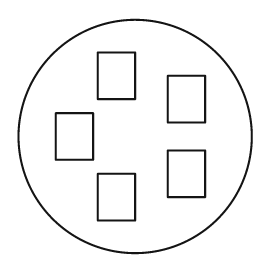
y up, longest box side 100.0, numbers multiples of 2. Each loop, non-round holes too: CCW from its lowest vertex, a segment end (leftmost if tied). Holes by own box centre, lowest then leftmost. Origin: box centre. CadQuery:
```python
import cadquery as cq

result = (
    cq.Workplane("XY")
    .moveTo(0.0, 0.0)
    .circle(50.0)
    .moveTo(-16.0, -36.0)
    .lineTo(0.0, -36.0)
    .lineTo(0.0, -16.0)
    .lineTo(-16.0, -16.0)
    .close()
    .moveTo(14.0, -26.0)
    .lineTo(30.0, -26.0)
    .lineTo(30.0, -6.0)
    .lineTo(14.0, -6.0)
    .close()
    .moveTo(-34.0, -10.0)
    .lineTo(-18.0, -10.0)
    .lineTo(-18.0, 10.0)
    .lineTo(-34.0, 10.0)
    .close()
    .moveTo(14.0, 6.0)
    .lineTo(30.0, 6.0)
    .lineTo(30.0, 26.0)
    .lineTo(14.0, 26.0)
    .close()
    .moveTo(-16.0, 16.0)
    .lineTo(0.0, 16.0)
    .lineTo(0.0, 36.0)
    .lineTo(-16.0, 36.0)
    .close()
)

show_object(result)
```